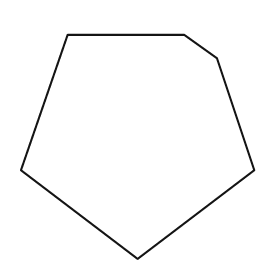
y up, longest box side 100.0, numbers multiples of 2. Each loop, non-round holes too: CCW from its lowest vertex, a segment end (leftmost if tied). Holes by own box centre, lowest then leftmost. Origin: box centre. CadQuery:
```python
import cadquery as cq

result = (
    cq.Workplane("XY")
    .moveTo(0.0, -48.0)
    .lineTo(50.0, -10.0)
    .lineTo(34.0, 38.0)
    .lineTo(20.0, 48.0)
    .lineTo(-30.0, 48.0)
    .lineTo(-50.0, -10.0)
    .close()
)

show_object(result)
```